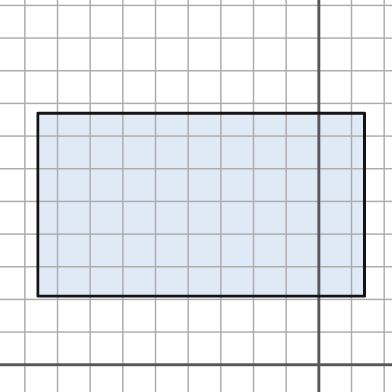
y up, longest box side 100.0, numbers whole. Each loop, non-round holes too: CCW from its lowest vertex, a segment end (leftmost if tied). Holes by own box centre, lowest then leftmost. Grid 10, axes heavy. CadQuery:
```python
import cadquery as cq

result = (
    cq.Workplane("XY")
    .moveTo(-86.0, 21.0)
    .lineTo(14.0, 21.0)
    .lineTo(14.0, 77.0)
    .lineTo(-86.0, 77.0)
    .close()
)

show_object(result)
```